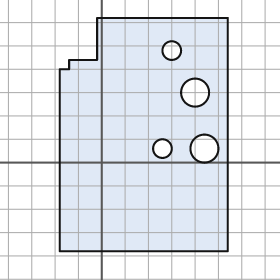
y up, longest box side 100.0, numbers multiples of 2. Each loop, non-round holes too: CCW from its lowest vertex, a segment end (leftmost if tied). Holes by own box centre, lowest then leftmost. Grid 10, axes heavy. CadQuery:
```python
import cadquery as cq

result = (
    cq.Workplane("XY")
    .moveTo(-18.0, -38.0)
    .lineTo(54.0, -38.0)
    .lineTo(54.0, 62.0)
    .lineTo(-2.0, 62.0)
    .lineTo(-2.0, 44.0)
    .lineTo(-14.0, 44.0)
    .lineTo(-14.0, 40.0)
    .lineTo(-18.0, 40.0)
    .close()
    .moveTo(26.0, 6.0)
    .circle(4.0)
    .moveTo(44.0, 6.0)
    .circle(6.0)
    .moveTo(40.0, 30.0)
    .circle(6.0)
    .moveTo(30.0, 48.0)
    .circle(4.0)
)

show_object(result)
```